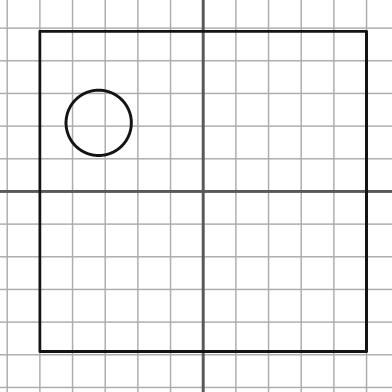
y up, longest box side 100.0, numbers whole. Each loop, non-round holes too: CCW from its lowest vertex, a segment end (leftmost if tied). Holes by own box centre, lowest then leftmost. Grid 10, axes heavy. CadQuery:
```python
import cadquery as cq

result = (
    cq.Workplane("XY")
    .moveTo(-50.0, -49.0)
    .lineTo(50.0, -49.0)
    .lineTo(50.0, 49.0)
    .lineTo(-50.0, 49.0)
    .close()
    .moveTo(-32.0, 21.0)
    .circle(10.0)
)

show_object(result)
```